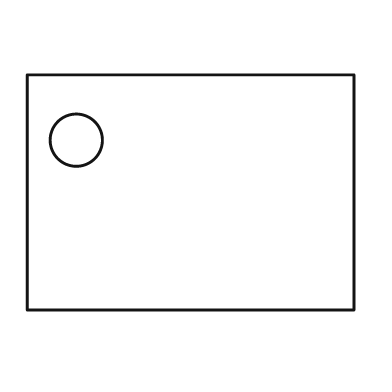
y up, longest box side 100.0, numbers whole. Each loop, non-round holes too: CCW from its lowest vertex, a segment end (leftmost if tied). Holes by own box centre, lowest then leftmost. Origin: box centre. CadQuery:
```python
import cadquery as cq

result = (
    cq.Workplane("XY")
    .moveTo(-50.0, -36.0)
    .lineTo(50.0, -36.0)
    .lineTo(50.0, 36.0)
    .lineTo(-50.0, 36.0)
    .close()
    .moveTo(-35.0, 16.0)
    .circle(8.0)
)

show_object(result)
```